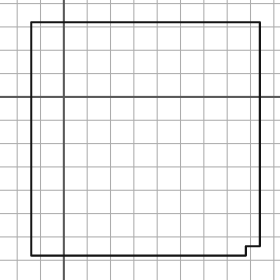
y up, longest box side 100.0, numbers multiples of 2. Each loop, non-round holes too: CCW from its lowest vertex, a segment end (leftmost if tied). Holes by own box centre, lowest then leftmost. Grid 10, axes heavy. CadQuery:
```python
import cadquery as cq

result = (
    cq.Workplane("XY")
    .moveTo(-14.0, -68.0)
    .lineTo(78.0, -68.0)
    .lineTo(78.0, -64.0)
    .lineTo(84.0, -64.0)
    .lineTo(84.0, 32.0)
    .lineTo(-14.0, 32.0)
    .close()
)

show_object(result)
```